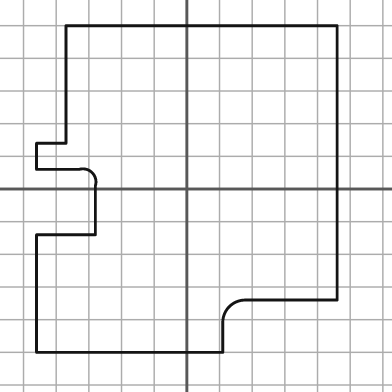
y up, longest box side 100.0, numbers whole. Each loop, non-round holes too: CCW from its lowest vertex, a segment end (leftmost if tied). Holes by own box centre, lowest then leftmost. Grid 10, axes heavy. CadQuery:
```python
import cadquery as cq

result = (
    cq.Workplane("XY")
    .moveTo(-46.0, -50.0)
    .lineTo(11.0, -50.0)
    .lineTo(11.0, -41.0)
    .threePointArc((13.0, -36.0), (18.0, -34.0))
    .lineTo(46.0, -34.0)
    .lineTo(46.0, 50.0)
    .lineTo(-37.0, 50.0)
    .lineTo(-37.0, 14.0)
    .lineTo(-46.0, 14.0)
    .lineTo(-46.0, 6.0)
    .lineTo(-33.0, 6.0)
    .threePointArc((-29.0, 5.0), (-28.0, 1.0))
    .lineTo(-28.0, -14.0)
    .lineTo(-46.0, -14.0)
    .close()
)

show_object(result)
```